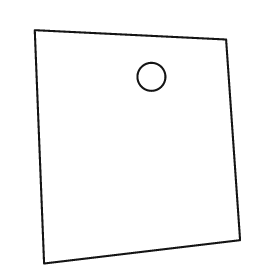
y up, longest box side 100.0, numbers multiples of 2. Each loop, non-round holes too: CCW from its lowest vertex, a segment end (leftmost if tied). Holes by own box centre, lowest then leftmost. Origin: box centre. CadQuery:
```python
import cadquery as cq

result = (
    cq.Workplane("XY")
    .moveTo(-40.0, -50.0)
    .lineTo(44.0, -40.0)
    .lineTo(38.0, 46.0)
    .lineTo(-44.0, 50.0)
    .close()
    .moveTo(6.0, 30.0)
    .circle(6.0)
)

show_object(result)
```